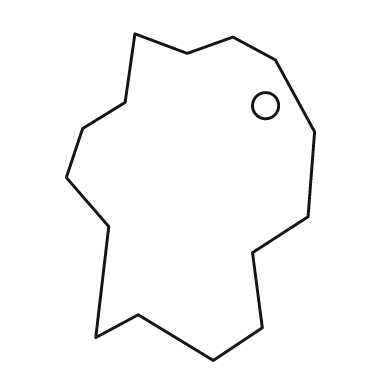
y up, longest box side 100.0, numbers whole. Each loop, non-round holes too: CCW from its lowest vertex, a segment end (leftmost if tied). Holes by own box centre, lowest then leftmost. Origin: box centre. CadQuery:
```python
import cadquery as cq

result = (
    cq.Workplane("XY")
    .moveTo(7.0, -50.0)
    .lineTo(22.0, -40.0)
    .lineTo(19.0, -17.0)
    .lineTo(36.0, -6.0)
    .lineTo(38.0, 20.0)
    .lineTo(26.0, 42.0)
    .lineTo(13.0, 49.0)
    .lineTo(-1.0, 44.0)
    .lineTo(-17.0, 50.0)
    .lineTo(-20.0, 29.0)
    .lineTo(-33.0, 21.0)
    .lineTo(-38.0, 6.0)
    .lineTo(-25.0, -9.0)
    .lineTo(-29.0, -43.0)
    .lineTo(-16.0, -36.0)
    .close()
    .moveTo(23.0, 28.0)
    .circle(4.0)
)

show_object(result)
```